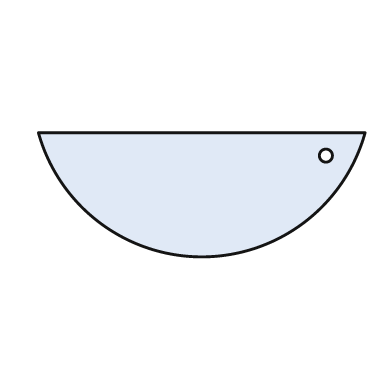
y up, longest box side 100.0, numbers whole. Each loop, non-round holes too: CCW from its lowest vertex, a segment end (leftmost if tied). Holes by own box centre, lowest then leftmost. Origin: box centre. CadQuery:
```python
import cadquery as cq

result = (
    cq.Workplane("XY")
    .moveTo(-50.0, 19.0)
    .threePointArc((0.0, -19.0), (50.0, 19.0))
    .close()
    .moveTo(38.0, 12.0)
    .circle(2.0)
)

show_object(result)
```